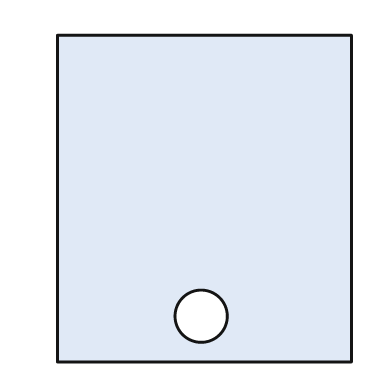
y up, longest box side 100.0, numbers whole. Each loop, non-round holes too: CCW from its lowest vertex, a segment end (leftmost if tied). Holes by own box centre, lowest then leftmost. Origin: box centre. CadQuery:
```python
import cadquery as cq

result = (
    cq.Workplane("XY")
    .moveTo(-45.0, -50.0)
    .lineTo(45.0, -50.0)
    .lineTo(45.0, 50.0)
    .lineTo(-45.0, 50.0)
    .close()
    .moveTo(-1.0, -36.0)
    .circle(8.0)
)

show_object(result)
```